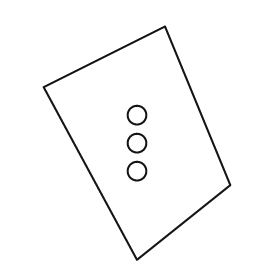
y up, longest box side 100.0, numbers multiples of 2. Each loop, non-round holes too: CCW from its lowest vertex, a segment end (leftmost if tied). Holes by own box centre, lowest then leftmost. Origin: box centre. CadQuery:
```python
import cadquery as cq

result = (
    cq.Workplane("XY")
    .moveTo(0.0, -50.0)
    .lineTo(40.0, -18.0)
    .lineTo(12.0, 50.0)
    .lineTo(-40.0, 24.0)
    .close()
    .moveTo(0.0, -12.0)
    .circle(4.0)
    .moveTo(0.0, 0.0)
    .circle(4.0)
    .moveTo(0.0, 12.0)
    .circle(4.0)
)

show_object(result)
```